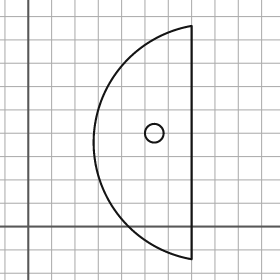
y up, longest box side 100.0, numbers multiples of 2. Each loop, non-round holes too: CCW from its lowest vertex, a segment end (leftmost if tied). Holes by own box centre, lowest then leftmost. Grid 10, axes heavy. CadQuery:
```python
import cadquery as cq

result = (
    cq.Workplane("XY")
    .moveTo(70.0, -14.0)
    .lineTo(70.0, 86.0)
    .threePointArc((28.0, 36.0), (70.0, -14.0))
    .close()
    .moveTo(54.0, 40.0)
    .circle(4.0)
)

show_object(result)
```